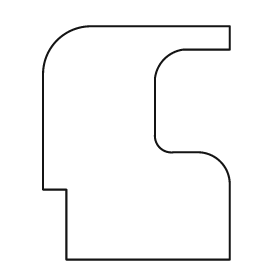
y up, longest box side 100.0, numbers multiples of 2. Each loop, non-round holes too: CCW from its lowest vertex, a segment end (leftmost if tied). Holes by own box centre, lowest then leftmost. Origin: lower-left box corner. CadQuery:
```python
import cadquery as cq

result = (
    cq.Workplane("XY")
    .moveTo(10.0, 0.0)
    .lineTo(80.0, 0.0)
    .lineTo(80.0, 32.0)
    .threePointArc((76.0, 42.0), (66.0, 46.0))
    .lineTo(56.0, 46.0)
    .threePointArc((50.0, 48.0), (48.0, 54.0))
    .lineTo(48.0, 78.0)
    .threePointArc((52.0, 86.0), (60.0, 90.0))
    .lineTo(80.0, 90.0)
    .lineTo(80.0, 100.0)
    .lineTo(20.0, 100.0)
    .threePointArc((6.0, 94.0), (0.0, 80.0))
    .lineTo(0.0, 30.0)
    .lineTo(10.0, 30.0)
    .close()
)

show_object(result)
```